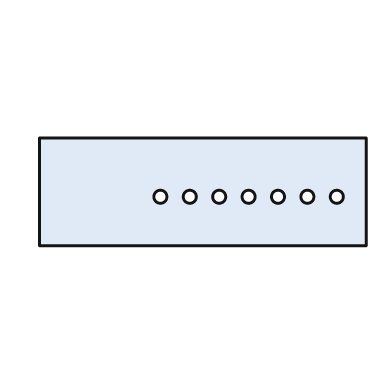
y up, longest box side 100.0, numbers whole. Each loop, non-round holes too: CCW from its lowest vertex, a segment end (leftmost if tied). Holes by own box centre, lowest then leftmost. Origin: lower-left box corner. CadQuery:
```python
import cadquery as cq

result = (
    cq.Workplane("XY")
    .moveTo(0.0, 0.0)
    .lineTo(100.0, 0.0)
    .lineTo(100.0, 33.0)
    .lineTo(0.0, 33.0)
    .close()
    .moveTo(37.0, 15.0)
    .circle(2.0)
    .moveTo(46.0, 15.0)
    .circle(2.0)
    .moveTo(55.0, 15.0)
    .circle(2.0)
    .moveTo(64.0, 15.0)
    .circle(2.0)
    .moveTo(73.0, 15.0)
    .circle(2.0)
    .moveTo(82.0, 15.0)
    .circle(2.0)
    .moveTo(91.0, 15.0)
    .circle(2.0)
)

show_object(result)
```